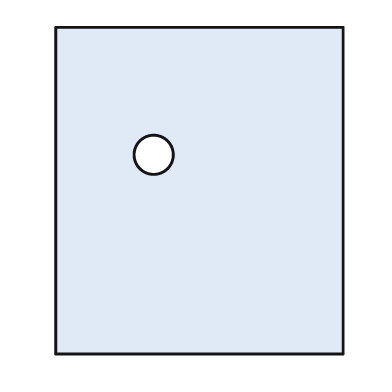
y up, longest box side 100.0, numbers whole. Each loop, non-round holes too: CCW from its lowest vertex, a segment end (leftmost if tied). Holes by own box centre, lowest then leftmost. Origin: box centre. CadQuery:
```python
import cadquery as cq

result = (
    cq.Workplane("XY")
    .moveTo(-44.0, -50.0)
    .lineTo(44.0, -50.0)
    .lineTo(44.0, 50.0)
    .lineTo(-44.0, 50.0)
    .close()
    .moveTo(-14.0, 11.0)
    .circle(6.0)
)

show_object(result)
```